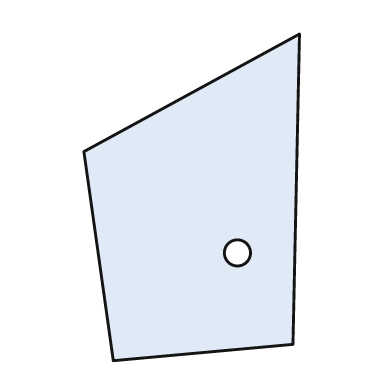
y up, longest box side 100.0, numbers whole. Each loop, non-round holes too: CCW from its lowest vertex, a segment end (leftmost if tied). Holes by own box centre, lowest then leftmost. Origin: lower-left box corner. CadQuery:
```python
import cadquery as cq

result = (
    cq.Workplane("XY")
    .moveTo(9.0, 0.0)
    .lineTo(64.0, 5.0)
    .lineTo(66.0, 100.0)
    .lineTo(0.0, 64.0)
    .close()
    .moveTo(47.0, 33.0)
    .circle(4.0)
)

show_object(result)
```